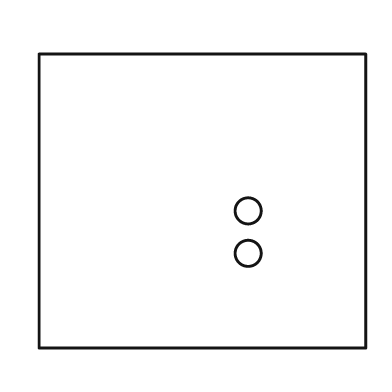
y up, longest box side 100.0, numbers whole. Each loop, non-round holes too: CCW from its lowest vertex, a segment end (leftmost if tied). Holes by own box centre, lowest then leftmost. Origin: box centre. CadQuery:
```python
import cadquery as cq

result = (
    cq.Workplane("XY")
    .moveTo(-50.0, -45.0)
    .lineTo(50.0, -45.0)
    .lineTo(50.0, 45.0)
    .lineTo(-50.0, 45.0)
    .close()
    .moveTo(14.0, -16.0)
    .circle(4.0)
    .moveTo(14.0, -3.0)
    .circle(4.0)
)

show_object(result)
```